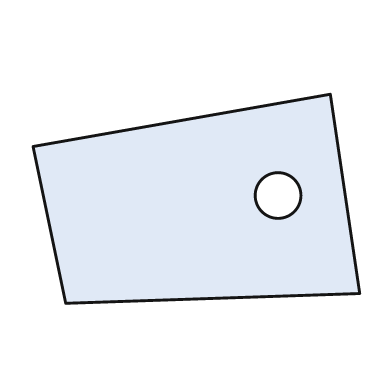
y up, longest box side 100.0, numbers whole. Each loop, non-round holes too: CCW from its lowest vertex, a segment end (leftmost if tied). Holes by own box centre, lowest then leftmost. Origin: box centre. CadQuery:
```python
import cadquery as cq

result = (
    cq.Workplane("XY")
    .moveTo(-40.0, -32.0)
    .lineTo(50.0, -29.0)
    .lineTo(41.0, 32.0)
    .lineTo(-50.0, 16.0)
    .close()
    .moveTo(25.0, 1.0)
    .circle(7.0)
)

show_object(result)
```